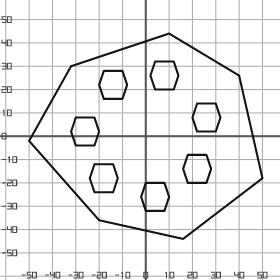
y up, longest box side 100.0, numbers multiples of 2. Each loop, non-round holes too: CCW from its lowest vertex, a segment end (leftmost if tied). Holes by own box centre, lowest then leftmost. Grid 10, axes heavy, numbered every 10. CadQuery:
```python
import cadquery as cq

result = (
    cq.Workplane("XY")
    .moveTo(16.0, -44.0)
    .lineTo(50.0, -18.0)
    .lineTo(40.0, 26.0)
    .lineTo(10.0, 44.0)
    .lineTo(-32.0, 30.0)
    .lineTo(-50.0, -2.0)
    .lineTo(-20.0, -36.0)
    .close()
    .moveTo(0.0, -32.0)
    .lineTo(8.0, -32.0)
    .lineTo(10.0, -26.0)
    .lineTo(8.0, -20.0)
    .lineTo(0.0, -20.0)
    .lineTo(-2.0, -26.0)
    .close()
    .moveTo(-22.0, -24.0)
    .lineTo(-14.0, -24.0)
    .lineTo(-12.0, -18.0)
    .lineTo(-14.0, -12.0)
    .lineTo(-22.0, -12.0)
    .lineTo(-24.0, -18.0)
    .close()
    .moveTo(18.0, -20.0)
    .lineTo(26.0, -20.0)
    .lineTo(28.0, -14.0)
    .lineTo(26.0, -8.0)
    .lineTo(18.0, -8.0)
    .lineTo(16.0, -14.0)
    .close()
    .moveTo(-30.0, -4.0)
    .lineTo(-22.0, -4.0)
    .lineTo(-20.0, 2.0)
    .lineTo(-22.0, 8.0)
    .lineTo(-30.0, 8.0)
    .lineTo(-32.0, 2.0)
    .close()
    .moveTo(22.0, 2.0)
    .lineTo(30.0, 2.0)
    .lineTo(32.0, 8.0)
    .lineTo(30.0, 14.0)
    .lineTo(22.0, 14.0)
    .lineTo(20.0, 8.0)
    .close()
    .moveTo(-18.0, 16.0)
    .lineTo(-10.0, 16.0)
    .lineTo(-8.0, 22.0)
    .lineTo(-10.0, 28.0)
    .lineTo(-18.0, 28.0)
    .lineTo(-20.0, 22.0)
    .close()
    .moveTo(4.0, 20.0)
    .lineTo(12.0, 20.0)
    .lineTo(14.0, 26.0)
    .lineTo(12.0, 32.0)
    .lineTo(4.0, 32.0)
    .lineTo(2.0, 26.0)
    .close()
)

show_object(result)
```